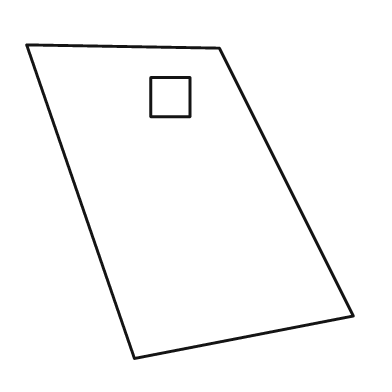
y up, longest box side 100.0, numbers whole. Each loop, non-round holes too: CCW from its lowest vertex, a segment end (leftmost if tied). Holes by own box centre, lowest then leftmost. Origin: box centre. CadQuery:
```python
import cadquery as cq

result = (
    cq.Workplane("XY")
    .moveTo(-17.0, -48.0)
    .lineTo(50.0, -35.0)
    .lineTo(9.0, 47.0)
    .lineTo(-50.0, 48.0)
    .close()
    .moveTo(-12.0, 26.0)
    .lineTo(0.0, 26.0)
    .lineTo(0.0, 38.0)
    .lineTo(-12.0, 38.0)
    .close()
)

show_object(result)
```